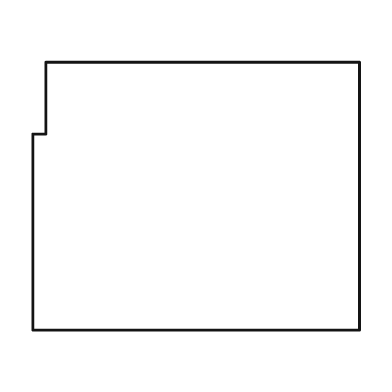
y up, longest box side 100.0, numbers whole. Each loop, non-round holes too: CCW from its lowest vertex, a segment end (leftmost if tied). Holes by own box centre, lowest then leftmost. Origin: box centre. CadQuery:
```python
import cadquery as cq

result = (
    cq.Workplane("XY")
    .moveTo(-50.0, -41.0)
    .lineTo(50.0, -41.0)
    .lineTo(50.0, 41.0)
    .lineTo(-46.0, 41.0)
    .lineTo(-46.0, 19.0)
    .lineTo(-50.0, 19.0)
    .close()
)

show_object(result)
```